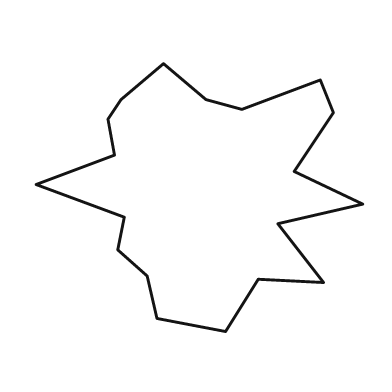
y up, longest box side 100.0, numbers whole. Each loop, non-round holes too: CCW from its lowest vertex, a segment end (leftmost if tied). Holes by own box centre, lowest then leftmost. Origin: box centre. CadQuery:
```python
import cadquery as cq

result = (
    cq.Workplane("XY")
    .moveTo(8.0, -41.0)
    .lineTo(18.0, -25.0)
    .lineTo(38.0, -26.0)
    .lineTo(24.0, -8.0)
    .lineTo(50.0, -2.0)
    .lineTo(29.0, 8.0)
    .lineTo(41.0, 26.0)
    .lineTo(37.0, 36.0)
    .lineTo(13.0, 27.0)
    .lineTo(2.0, 30.0)
    .lineTo(-11.0, 41.0)
    .lineTo(-24.0, 30.0)
    .lineTo(-28.0, 24.0)
    .lineTo(-26.0, 13.0)
    .lineTo(-50.0, 4.0)
    .lineTo(-23.0, -6.0)
    .lineTo(-25.0, -16.0)
    .lineTo(-16.0, -24.0)
    .lineTo(-13.0, -37.0)
    .close()
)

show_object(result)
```